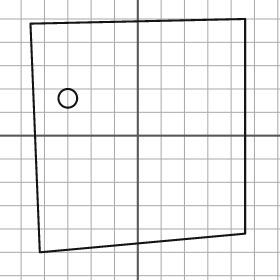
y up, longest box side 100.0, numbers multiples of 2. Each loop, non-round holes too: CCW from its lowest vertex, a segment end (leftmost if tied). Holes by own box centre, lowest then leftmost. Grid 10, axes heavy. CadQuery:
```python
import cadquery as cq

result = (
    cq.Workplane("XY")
    .moveTo(-42.0, -50.0)
    .lineTo(46.0, -42.0)
    .lineTo(46.0, 50.0)
    .lineTo(-46.0, 48.0)
    .close()
    .moveTo(-30.0, 16.0)
    .circle(4.0)
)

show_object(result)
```